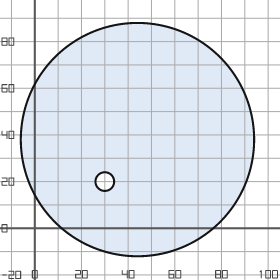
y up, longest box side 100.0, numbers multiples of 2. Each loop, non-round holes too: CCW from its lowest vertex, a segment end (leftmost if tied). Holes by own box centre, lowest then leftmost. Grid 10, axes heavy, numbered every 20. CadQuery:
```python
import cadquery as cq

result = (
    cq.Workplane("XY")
    .moveTo(44.0, 38.0)
    .circle(50.0)
    .moveTo(30.0, 20.0)
    .circle(4.0)
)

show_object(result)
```